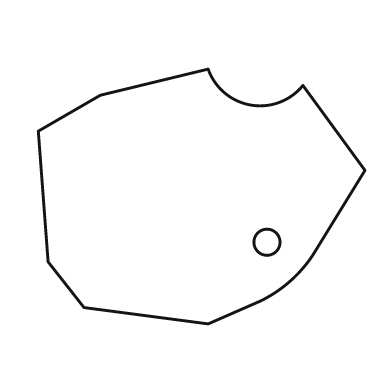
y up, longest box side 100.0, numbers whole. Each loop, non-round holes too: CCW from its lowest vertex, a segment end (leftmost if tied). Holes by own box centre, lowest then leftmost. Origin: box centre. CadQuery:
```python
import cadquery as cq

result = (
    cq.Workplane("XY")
    .moveTo(2.0, -39.0)
    .lineTo(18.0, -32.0)
    .threePointArc((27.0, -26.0), (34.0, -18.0))
    .lineTo(50.0, 8.0)
    .lineTo(31.0, 34.0)
    .threePointArc((15.0, 28.0), (2.0, 39.0))
    .lineTo(-31.0, 31.0)
    .lineTo(-50.0, 20.0)
    .lineTo(-47.0, -20.0)
    .lineTo(-36.0, -34.0)
    .close()
    .moveTo(20.0, -14.0)
    .circle(4.0)
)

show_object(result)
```